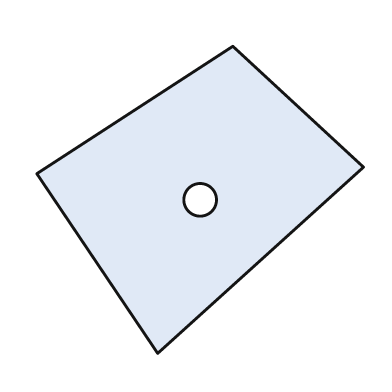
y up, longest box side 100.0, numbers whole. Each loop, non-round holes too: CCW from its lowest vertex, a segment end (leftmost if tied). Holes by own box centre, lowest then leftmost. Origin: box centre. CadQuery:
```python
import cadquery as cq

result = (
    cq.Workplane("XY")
    .moveTo(-13.0, -47.0)
    .lineTo(50.0, 10.0)
    .lineTo(10.0, 47.0)
    .lineTo(-50.0, 8.0)
    .close()
    .moveTo(0.0, 0.0)
    .circle(5.0)
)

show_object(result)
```